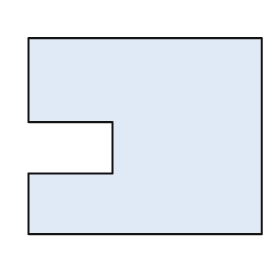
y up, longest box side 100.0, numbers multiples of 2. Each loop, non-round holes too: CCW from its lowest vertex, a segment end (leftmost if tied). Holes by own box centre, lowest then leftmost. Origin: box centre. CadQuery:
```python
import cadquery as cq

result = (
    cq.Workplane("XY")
    .moveTo(-50.0, -42.0)
    .lineTo(50.0, -42.0)
    .lineTo(50.0, 42.0)
    .lineTo(-50.0, 42.0)
    .lineTo(-50.0, 6.0)
    .lineTo(-14.0, 6.0)
    .lineTo(-14.0, -16.0)
    .lineTo(-50.0, -16.0)
    .close()
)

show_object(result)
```